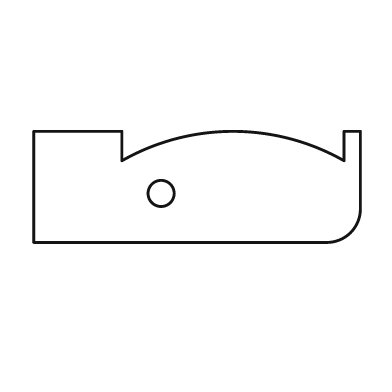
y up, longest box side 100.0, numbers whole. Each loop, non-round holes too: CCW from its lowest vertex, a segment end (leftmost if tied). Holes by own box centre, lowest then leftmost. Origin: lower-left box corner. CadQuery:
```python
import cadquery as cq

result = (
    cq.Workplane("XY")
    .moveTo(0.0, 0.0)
    .lineTo(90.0, 0.0)
    .threePointArc((97.0, 3.0), (100.0, 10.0))
    .lineTo(100.0, 34.0)
    .lineTo(95.0, 34.0)
    .lineTo(95.0, 25.0)
    .threePointArc((61.0, 34.0), (27.0, 25.0))
    .lineTo(27.0, 34.0)
    .lineTo(0.0, 34.0)
    .close()
    .moveTo(39.0, 15.0)
    .circle(4.0)
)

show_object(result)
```